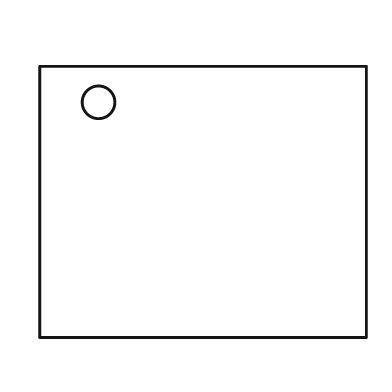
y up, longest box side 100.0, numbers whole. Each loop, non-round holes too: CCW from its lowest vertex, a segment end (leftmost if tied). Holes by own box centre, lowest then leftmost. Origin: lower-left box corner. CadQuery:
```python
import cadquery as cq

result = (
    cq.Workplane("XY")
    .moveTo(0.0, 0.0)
    .lineTo(100.0, 0.0)
    .lineTo(100.0, 83.0)
    .lineTo(0.0, 83.0)
    .close()
    .moveTo(18.0, 72.0)
    .circle(5.0)
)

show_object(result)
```